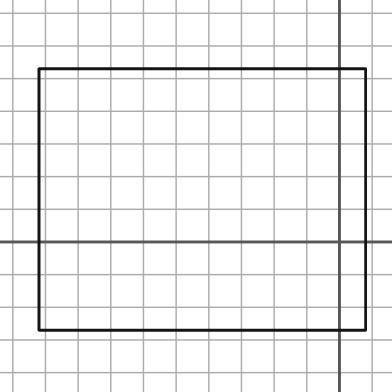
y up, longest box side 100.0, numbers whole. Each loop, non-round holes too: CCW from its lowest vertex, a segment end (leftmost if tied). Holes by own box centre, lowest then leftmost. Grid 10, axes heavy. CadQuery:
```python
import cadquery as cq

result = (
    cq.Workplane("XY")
    .moveTo(-92.0, -27.0)
    .lineTo(8.0, -27.0)
    .lineTo(8.0, 53.0)
    .lineTo(-92.0, 53.0)
    .close()
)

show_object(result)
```